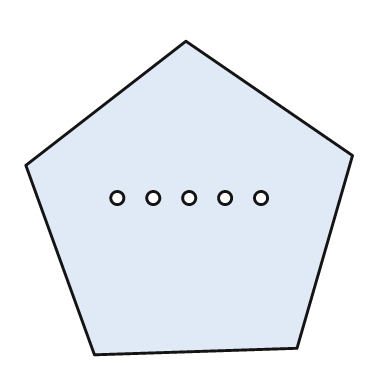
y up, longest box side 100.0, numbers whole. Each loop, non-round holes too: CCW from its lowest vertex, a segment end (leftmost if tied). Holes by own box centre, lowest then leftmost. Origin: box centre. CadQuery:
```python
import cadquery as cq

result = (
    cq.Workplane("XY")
    .moveTo(-29.0, -48.0)
    .lineTo(33.0, -46.0)
    .lineTo(50.0, 13.0)
    .lineTo(-1.0, 48.0)
    .lineTo(-50.0, 10.0)
    .close()
    .moveTo(-22.0, 0.0)
    .circle(2.0)
    .moveTo(-11.0, 0.0)
    .circle(2.0)
    .moveTo(0.0, 0.0)
    .circle(2.0)
    .moveTo(11.0, 0.0)
    .circle(2.0)
    .moveTo(22.0, 0.0)
    .circle(2.0)
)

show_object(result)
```